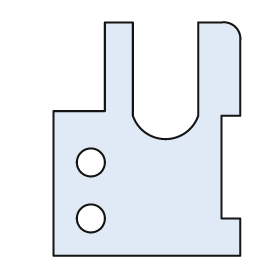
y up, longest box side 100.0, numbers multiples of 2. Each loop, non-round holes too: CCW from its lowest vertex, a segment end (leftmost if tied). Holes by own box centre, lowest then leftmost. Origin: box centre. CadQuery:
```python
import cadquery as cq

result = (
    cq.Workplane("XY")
    .moveTo(-40.0, -50.0)
    .lineTo(40.0, -50.0)
    .lineTo(40.0, -34.0)
    .lineTo(32.0, -34.0)
    .lineTo(32.0, 10.0)
    .lineTo(40.0, 10.0)
    .lineTo(40.0, 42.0)
    .threePointArc((38.0, 48.0), (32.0, 50.0))
    .lineTo(22.0, 50.0)
    .lineTo(22.0, 10.0)
    .threePointArc((8.0, 0.0), (-6.0, 10.0))
    .lineTo(-6.0, 50.0)
    .lineTo(-18.0, 50.0)
    .lineTo(-18.0, 12.0)
    .lineTo(-40.0, 12.0)
    .close()
    .moveTo(-24.0, -34.0)
    .circle(6.0)
    .moveTo(-24.0, -10.0)
    .circle(6.0)
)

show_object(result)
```